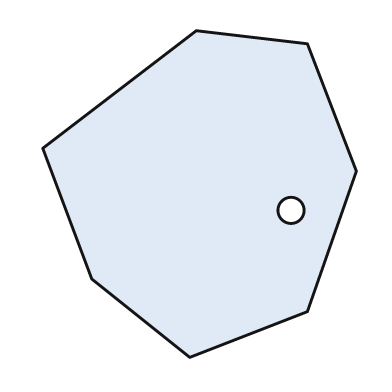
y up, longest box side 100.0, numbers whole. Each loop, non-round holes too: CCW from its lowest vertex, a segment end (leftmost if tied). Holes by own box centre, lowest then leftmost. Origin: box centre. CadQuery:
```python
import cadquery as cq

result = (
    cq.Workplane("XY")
    .moveTo(-3.0, -50.0)
    .lineTo(33.0, -36.0)
    .lineTo(48.0, 7.0)
    .lineTo(33.0, 46.0)
    .lineTo(-1.0, 50.0)
    .lineTo(-48.0, 14.0)
    .lineTo(-33.0, -26.0)
    .close()
    .moveTo(28.0, -5.0)
    .circle(4.0)
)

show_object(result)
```